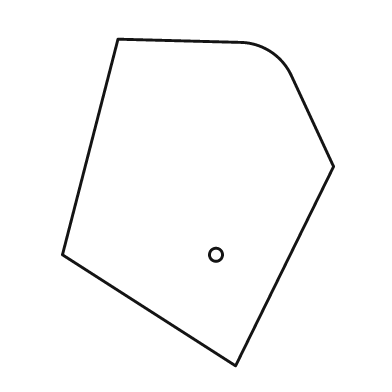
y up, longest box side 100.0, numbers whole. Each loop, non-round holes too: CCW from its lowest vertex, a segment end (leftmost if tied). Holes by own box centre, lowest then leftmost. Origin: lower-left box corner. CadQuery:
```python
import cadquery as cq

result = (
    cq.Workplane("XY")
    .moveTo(53.0, 0.0)
    .lineTo(83.0, 61.0)
    .lineTo(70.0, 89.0)
    .threePointArc((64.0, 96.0), (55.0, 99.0))
    .lineTo(17.0, 100.0)
    .lineTo(0.0, 34.0)
    .close()
    .moveTo(47.0, 34.0)
    .circle(2.0)
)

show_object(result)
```